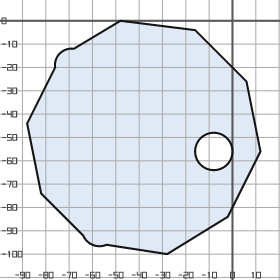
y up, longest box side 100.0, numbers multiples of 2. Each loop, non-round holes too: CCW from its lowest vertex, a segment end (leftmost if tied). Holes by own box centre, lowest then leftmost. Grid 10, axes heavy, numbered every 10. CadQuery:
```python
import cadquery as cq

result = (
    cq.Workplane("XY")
    .moveTo(-28.0, -100.0)
    .lineTo(-2.0, -84.0)
    .lineTo(12.0, -56.0)
    .lineTo(6.0, -26.0)
    .lineTo(-16.0, -4.0)
    .lineTo(-48.0, 0.0)
    .lineTo(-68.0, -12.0)
    .threePointArc((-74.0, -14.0), (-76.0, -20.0))
    .lineTo(-88.0, -44.0)
    .lineTo(-82.0, -74.0)
    .lineTo(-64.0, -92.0)
    .threePointArc((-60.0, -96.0), (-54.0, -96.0))
    .close()
    .moveTo(-8.0, -56.0)
    .circle(8.0)
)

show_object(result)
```